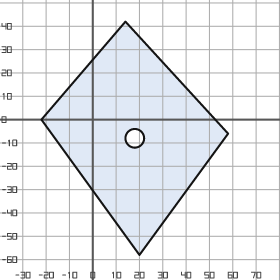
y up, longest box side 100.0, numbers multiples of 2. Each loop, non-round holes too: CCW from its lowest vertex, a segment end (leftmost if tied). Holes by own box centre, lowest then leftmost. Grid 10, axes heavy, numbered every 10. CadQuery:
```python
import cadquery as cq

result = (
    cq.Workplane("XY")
    .moveTo(20.0, -58.0)
    .lineTo(58.0, -6.0)
    .lineTo(14.0, 42.0)
    .lineTo(-22.0, 0.0)
    .close()
    .moveTo(18.0, -8.0)
    .circle(4.0)
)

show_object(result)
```